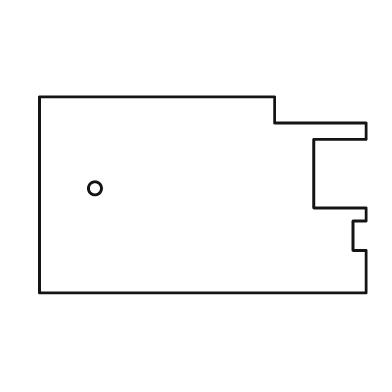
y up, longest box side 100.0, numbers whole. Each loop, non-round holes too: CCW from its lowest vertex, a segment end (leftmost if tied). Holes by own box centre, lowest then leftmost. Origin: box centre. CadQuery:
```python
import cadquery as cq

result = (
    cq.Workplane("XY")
    .moveTo(-50.0, -30.0)
    .lineTo(50.0, -30.0)
    .lineTo(50.0, -17.0)
    .lineTo(46.0, -17.0)
    .lineTo(46.0, -8.0)
    .lineTo(50.0, -8.0)
    .lineTo(50.0, -4.0)
    .lineTo(34.0, -4.0)
    .lineTo(34.0, 17.0)
    .lineTo(50.0, 17.0)
    .lineTo(50.0, 22.0)
    .lineTo(22.0, 22.0)
    .lineTo(22.0, 30.0)
    .lineTo(-50.0, 30.0)
    .close()
    .moveTo(-33.0, 2.0)
    .circle(2.0)
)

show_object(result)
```